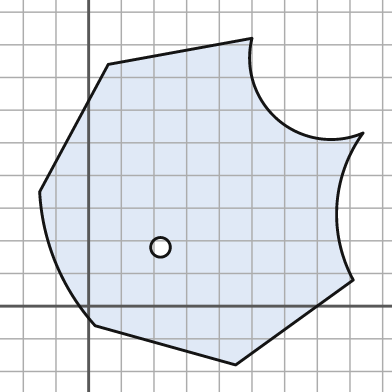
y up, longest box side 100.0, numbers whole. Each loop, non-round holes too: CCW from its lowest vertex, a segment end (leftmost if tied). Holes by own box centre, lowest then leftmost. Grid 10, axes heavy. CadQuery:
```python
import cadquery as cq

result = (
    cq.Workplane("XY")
    .moveTo(45.0, -18.0)
    .lineTo(81.0, 8.0)
    .threePointArc((76.0, 31.0), (84.0, 53.0))
    .threePointArc((58.0, 57.0), (50.0, 82.0))
    .lineTo(6.0, 74.0)
    .lineTo(-15.0, 35.0)
    .threePointArc((-10.0, 13.0), (2.0, -6.0))
    .close()
    .moveTo(22.0, 18.0)
    .circle(3.0)
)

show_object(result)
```